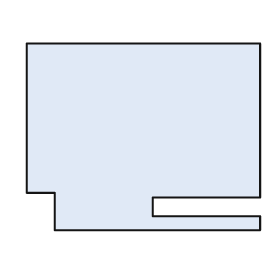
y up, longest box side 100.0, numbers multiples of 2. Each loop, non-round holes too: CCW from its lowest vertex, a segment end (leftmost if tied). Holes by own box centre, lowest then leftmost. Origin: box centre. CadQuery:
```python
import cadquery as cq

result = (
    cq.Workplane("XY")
    .moveTo(-38.0, -40.0)
    .lineTo(50.0, -40.0)
    .lineTo(50.0, -34.0)
    .lineTo(4.0, -34.0)
    .lineTo(4.0, -26.0)
    .lineTo(50.0, -26.0)
    .lineTo(50.0, 40.0)
    .lineTo(-50.0, 40.0)
    .lineTo(-50.0, -24.0)
    .lineTo(-38.0, -24.0)
    .close()
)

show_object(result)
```